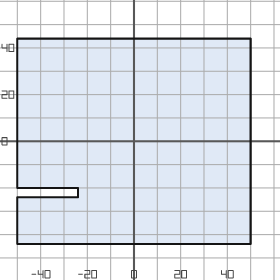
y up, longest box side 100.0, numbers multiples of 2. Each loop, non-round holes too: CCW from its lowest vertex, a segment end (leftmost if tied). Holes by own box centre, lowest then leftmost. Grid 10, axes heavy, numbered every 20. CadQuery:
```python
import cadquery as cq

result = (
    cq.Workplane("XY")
    .moveTo(-50.0, -44.0)
    .lineTo(50.0, -44.0)
    .lineTo(50.0, 44.0)
    .lineTo(-50.0, 44.0)
    .lineTo(-50.0, -20.0)
    .lineTo(-24.0, -20.0)
    .lineTo(-24.0, -24.0)
    .lineTo(-50.0, -24.0)
    .close()
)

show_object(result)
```